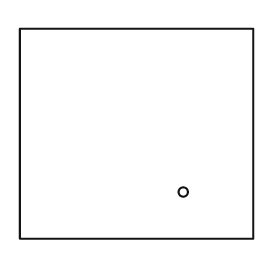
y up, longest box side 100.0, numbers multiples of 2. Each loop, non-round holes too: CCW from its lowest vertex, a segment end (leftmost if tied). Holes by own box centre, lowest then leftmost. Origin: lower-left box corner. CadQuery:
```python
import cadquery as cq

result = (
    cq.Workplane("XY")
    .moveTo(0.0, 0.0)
    .lineTo(100.0, 0.0)
    .lineTo(100.0, 90.0)
    .lineTo(0.0, 90.0)
    .close()
    .moveTo(70.0, 20.0)
    .circle(2.0)
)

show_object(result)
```